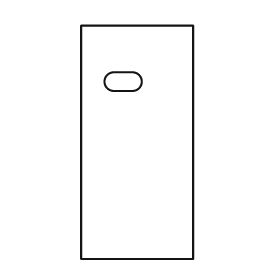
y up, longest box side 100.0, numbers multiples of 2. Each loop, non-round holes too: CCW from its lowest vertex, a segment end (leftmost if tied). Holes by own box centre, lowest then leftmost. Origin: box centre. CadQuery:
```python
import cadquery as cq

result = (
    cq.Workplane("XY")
    .moveTo(-24.0, -50.0)
    .lineTo(24.0, -50.0)
    .lineTo(24.0, 50.0)
    .lineTo(-24.0, 50.0)
    .close()
    .moveTo(-10.0, 22.0)
    .lineTo(-2.0, 22.0)
    .threePointArc((2.0, 26.0), (-2.0, 30.0))
    .lineTo(-10.0, 30.0)
    .threePointArc((-14.0, 26.0), (-10.0, 22.0))
    .close()
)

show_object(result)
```